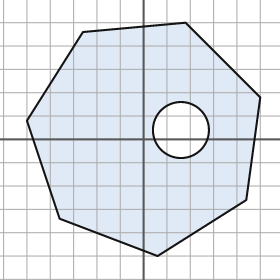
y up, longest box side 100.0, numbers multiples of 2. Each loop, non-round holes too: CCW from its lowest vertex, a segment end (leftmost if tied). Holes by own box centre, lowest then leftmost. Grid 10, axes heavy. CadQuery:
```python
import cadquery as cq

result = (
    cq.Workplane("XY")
    .moveTo(6.0, -50.0)
    .lineTo(44.0, -26.0)
    .lineTo(50.0, 18.0)
    .lineTo(18.0, 50.0)
    .lineTo(-26.0, 46.0)
    .lineTo(-50.0, 8.0)
    .lineTo(-36.0, -34.0)
    .close()
    .moveTo(16.0, 4.0)
    .circle(12.0)
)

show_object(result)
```